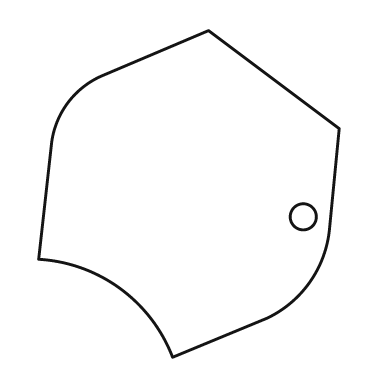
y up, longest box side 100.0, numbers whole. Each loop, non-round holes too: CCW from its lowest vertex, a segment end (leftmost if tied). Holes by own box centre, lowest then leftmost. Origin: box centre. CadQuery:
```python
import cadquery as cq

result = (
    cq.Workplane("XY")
    .moveTo(-5.0, -50.0)
    .lineTo(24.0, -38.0)
    .threePointArc((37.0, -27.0), (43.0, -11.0))
    .lineTo(46.0, 20.0)
    .lineTo(6.0, 50.0)
    .lineTo(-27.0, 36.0)
    .threePointArc((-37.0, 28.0), (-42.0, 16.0))
    .lineTo(-46.0, -20.0)
    .threePointArc((-21.0, -29.0), (-5.0, -50.0))
    .close()
    .moveTo(35.0, -7.0)
    .circle(4.0)
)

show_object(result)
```